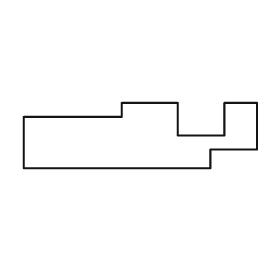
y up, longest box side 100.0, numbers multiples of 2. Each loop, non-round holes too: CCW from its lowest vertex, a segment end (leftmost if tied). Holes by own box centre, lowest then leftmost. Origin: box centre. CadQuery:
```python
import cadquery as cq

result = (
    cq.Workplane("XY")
    .moveTo(-50.0, -14.0)
    .lineTo(30.0, -14.0)
    .lineTo(30.0, -6.0)
    .lineTo(50.0, -6.0)
    .lineTo(50.0, 14.0)
    .lineTo(36.0, 14.0)
    .lineTo(36.0, 0.0)
    .lineTo(16.0, 0.0)
    .lineTo(16.0, 14.0)
    .lineTo(-8.0, 14.0)
    .lineTo(-8.0, 8.0)
    .lineTo(-50.0, 8.0)
    .close()
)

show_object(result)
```